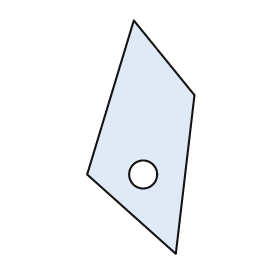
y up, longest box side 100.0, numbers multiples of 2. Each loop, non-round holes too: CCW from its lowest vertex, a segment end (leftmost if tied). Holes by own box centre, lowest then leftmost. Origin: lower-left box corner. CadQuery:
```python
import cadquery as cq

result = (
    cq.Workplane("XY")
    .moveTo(38.0, 0.0)
    .lineTo(46.0, 68.0)
    .lineTo(20.0, 100.0)
    .lineTo(0.0, 34.0)
    .close()
    .moveTo(24.0, 34.0)
    .circle(6.0)
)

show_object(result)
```